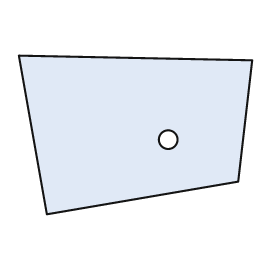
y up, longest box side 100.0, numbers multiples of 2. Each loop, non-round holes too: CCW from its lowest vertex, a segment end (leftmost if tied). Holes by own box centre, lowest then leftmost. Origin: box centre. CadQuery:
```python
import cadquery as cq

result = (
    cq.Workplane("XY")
    .moveTo(-38.0, -34.0)
    .lineTo(44.0, -20.0)
    .lineTo(50.0, 32.0)
    .lineTo(-50.0, 34.0)
    .close()
    .moveTo(14.0, -2.0)
    .circle(4.0)
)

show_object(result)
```